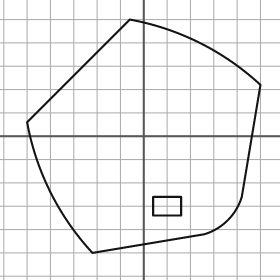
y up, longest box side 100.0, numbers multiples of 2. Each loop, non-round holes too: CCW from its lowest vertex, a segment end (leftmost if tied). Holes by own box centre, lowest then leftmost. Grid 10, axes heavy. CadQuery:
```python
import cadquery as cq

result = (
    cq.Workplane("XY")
    .moveTo(-22.0, -50.0)
    .lineTo(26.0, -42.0)
    .threePointArc((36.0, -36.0), (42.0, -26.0))
    .lineTo(50.0, 22.0)
    .threePointArc((24.0, 40.0), (-6.0, 50.0))
    .lineTo(-50.0, 6.0)
    .threePointArc((-40.0, -24.0), (-22.0, -50.0))
    .close()
    .moveTo(4.0, -34.0)
    .lineTo(16.0, -34.0)
    .lineTo(16.0, -26.0)
    .lineTo(4.0, -26.0)
    .close()
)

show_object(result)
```